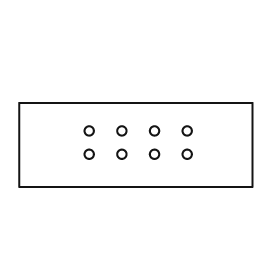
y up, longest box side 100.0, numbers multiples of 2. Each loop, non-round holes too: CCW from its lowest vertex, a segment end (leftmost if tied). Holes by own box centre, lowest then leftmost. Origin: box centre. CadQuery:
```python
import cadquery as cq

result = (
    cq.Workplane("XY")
    .moveTo(-50.0, -18.0)
    .lineTo(50.0, -18.0)
    .lineTo(50.0, 18.0)
    .lineTo(-50.0, 18.0)
    .close()
    .moveTo(-20.0, -4.0)
    .circle(2.0)
    .moveTo(-6.0, -4.0)
    .circle(2.0)
    .moveTo(8.0, -4.0)
    .circle(2.0)
    .moveTo(22.0, -4.0)
    .circle(2.0)
    .moveTo(-20.0, 6.0)
    .circle(2.0)
    .moveTo(-6.0, 6.0)
    .circle(2.0)
    .moveTo(8.0, 6.0)
    .circle(2.0)
    .moveTo(22.0, 6.0)
    .circle(2.0)
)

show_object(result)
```